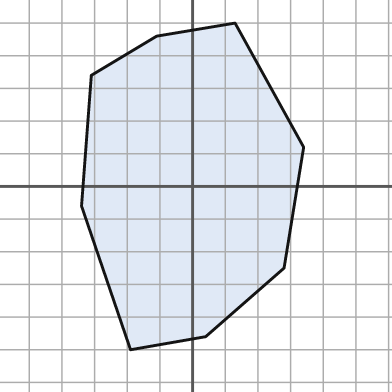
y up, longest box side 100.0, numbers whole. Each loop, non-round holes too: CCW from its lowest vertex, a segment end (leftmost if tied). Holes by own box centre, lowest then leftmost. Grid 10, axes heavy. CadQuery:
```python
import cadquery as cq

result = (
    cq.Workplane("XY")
    .moveTo(-19.0, -50.0)
    .lineTo(4.0, -46.0)
    .lineTo(28.0, -25.0)
    .lineTo(34.0, 12.0)
    .lineTo(13.0, 50.0)
    .lineTo(-11.0, 46.0)
    .lineTo(-31.0, 34.0)
    .lineTo(-34.0, -6.0)
    .close()
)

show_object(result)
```